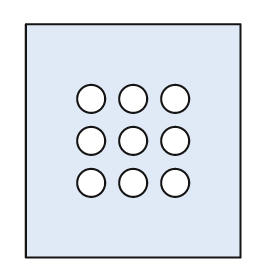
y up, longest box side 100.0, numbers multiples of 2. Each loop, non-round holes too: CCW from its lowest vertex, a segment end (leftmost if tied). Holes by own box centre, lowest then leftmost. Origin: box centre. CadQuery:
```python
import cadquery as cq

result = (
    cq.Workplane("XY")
    .moveTo(-46.0, -50.0)
    .lineTo(46.0, -50.0)
    .lineTo(46.0, 50.0)
    .lineTo(-46.0, 50.0)
    .close()
    .moveTo(-18.0, -18.0)
    .circle(6.0)
    .moveTo(0.0, -18.0)
    .circle(6.0)
    .moveTo(18.0, -18.0)
    .circle(6.0)
    .moveTo(-18.0, 0.0)
    .circle(6.0)
    .moveTo(0.0, 0.0)
    .circle(6.0)
    .moveTo(18.0, 0.0)
    .circle(6.0)
    .moveTo(-18.0, 18.0)
    .circle(6.0)
    .moveTo(0.0, 18.0)
    .circle(6.0)
    .moveTo(18.0, 18.0)
    .circle(6.0)
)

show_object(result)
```